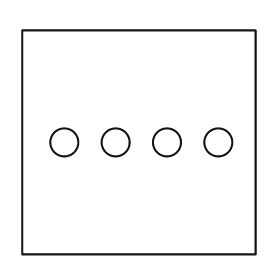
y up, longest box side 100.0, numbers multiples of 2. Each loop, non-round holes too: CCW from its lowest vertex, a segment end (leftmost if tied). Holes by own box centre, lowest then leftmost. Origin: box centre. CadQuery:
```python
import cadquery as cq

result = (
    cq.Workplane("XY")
    .moveTo(-50.0, -48.0)
    .lineTo(50.0, -48.0)
    .lineTo(50.0, 48.0)
    .lineTo(-50.0, 48.0)
    .close()
    .moveTo(-32.0, 0.0)
    .circle(6.0)
    .moveTo(-10.0, 0.0)
    .circle(6.0)
    .moveTo(12.0, 0.0)
    .circle(6.0)
    .moveTo(34.0, 0.0)
    .circle(6.0)
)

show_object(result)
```